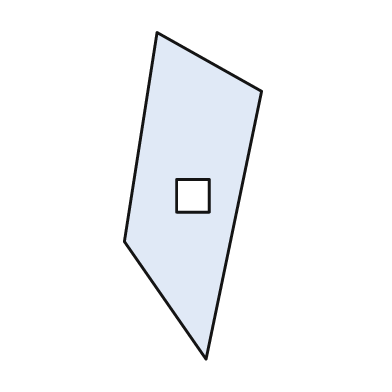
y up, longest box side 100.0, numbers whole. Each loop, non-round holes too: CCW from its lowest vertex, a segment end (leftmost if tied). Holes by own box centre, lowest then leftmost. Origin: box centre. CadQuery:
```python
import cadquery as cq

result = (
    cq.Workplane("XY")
    .moveTo(4.0, -50.0)
    .lineTo(21.0, 32.0)
    .lineTo(-11.0, 50.0)
    .lineTo(-21.0, -14.0)
    .close()
    .moveTo(-5.0, -5.0)
    .lineTo(5.0, -5.0)
    .lineTo(5.0, 5.0)
    .lineTo(-5.0, 5.0)
    .close()
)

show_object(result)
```